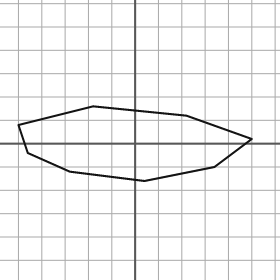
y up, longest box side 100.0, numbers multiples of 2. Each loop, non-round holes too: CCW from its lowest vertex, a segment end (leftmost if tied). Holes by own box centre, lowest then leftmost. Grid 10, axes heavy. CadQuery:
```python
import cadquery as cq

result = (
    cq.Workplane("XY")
    .moveTo(4.0, -16.0)
    .lineTo(34.0, -10.0)
    .lineTo(50.0, 2.0)
    .lineTo(22.0, 12.0)
    .lineTo(-18.0, 16.0)
    .lineTo(-50.0, 8.0)
    .lineTo(-46.0, -4.0)
    .lineTo(-28.0, -12.0)
    .close()
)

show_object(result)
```